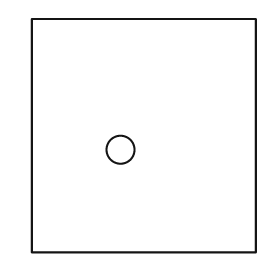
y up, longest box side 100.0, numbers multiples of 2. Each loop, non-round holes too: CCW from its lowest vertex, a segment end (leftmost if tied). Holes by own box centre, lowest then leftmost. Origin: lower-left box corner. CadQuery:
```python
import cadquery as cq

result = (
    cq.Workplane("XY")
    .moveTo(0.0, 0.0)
    .lineTo(96.0, 0.0)
    .lineTo(96.0, 100.0)
    .lineTo(0.0, 100.0)
    .close()
    .moveTo(38.0, 44.0)
    .circle(6.0)
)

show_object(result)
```